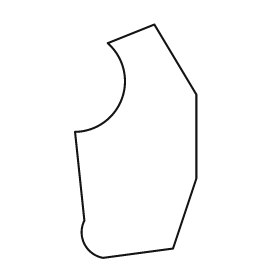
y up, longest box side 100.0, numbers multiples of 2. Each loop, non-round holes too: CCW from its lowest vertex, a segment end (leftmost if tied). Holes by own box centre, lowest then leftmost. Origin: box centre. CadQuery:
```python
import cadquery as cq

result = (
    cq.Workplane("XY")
    .moveTo(-14.0, -50.0)
    .lineTo(16.0, -46.0)
    .lineTo(26.0, -16.0)
    .lineTo(26.0, 20.0)
    .lineTo(8.0, 50.0)
    .lineTo(-12.0, 42.0)
    .threePointArc((-6.0, 18.0), (-26.0, 4.0))
    .lineTo(-22.0, -34.0)
    .threePointArc((-22.0, -44.0), (-14.0, -50.0))
    .close()
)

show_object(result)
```